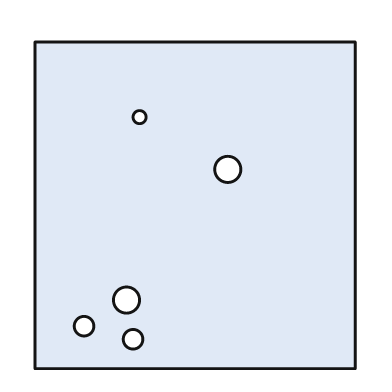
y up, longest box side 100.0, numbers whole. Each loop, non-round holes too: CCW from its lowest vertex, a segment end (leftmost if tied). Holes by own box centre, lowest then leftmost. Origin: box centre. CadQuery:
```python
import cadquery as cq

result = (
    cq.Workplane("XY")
    .moveTo(-49.0, -50.0)
    .lineTo(49.0, -50.0)
    .lineTo(49.0, 50.0)
    .lineTo(-49.0, 50.0)
    .close()
    .moveTo(-19.0, -41.0)
    .circle(3.0)
    .moveTo(-34.0, -37.0)
    .circle(3.0)
    .moveTo(-21.0, -29.0)
    .circle(4.0)
    .moveTo(10.0, 11.0)
    .circle(4.0)
    .moveTo(-17.0, 27.0)
    .circle(2.0)
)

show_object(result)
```